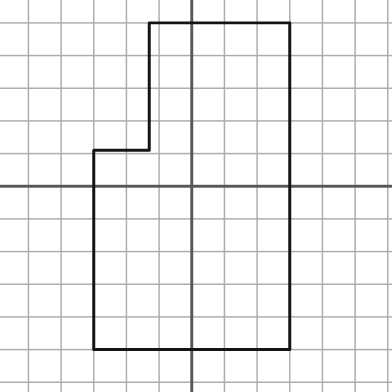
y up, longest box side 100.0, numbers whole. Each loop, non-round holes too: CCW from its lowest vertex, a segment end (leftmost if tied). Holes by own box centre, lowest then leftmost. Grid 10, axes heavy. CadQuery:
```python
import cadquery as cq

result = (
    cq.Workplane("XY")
    .moveTo(-30.0, -50.0)
    .lineTo(30.0, -50.0)
    .lineTo(30.0, 50.0)
    .lineTo(-13.0, 50.0)
    .lineTo(-13.0, 11.0)
    .lineTo(-30.0, 11.0)
    .close()
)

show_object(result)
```